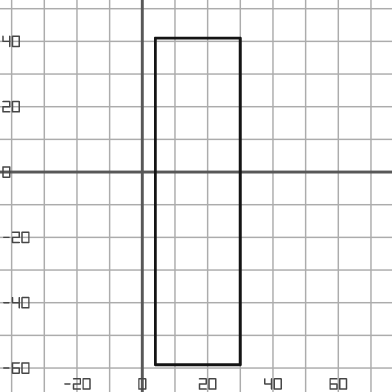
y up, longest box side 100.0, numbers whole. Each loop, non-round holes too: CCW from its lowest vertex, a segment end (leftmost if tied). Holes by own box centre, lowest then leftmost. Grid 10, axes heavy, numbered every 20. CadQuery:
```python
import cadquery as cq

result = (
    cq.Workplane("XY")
    .moveTo(4.0, -59.0)
    .lineTo(30.0, -59.0)
    .lineTo(30.0, 41.0)
    .lineTo(4.0, 41.0)
    .close()
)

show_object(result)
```